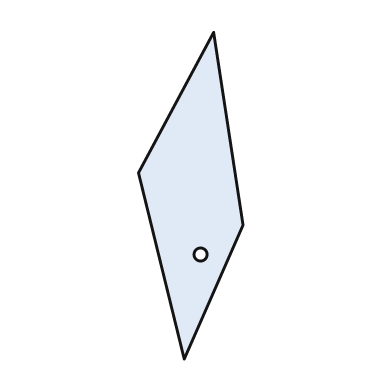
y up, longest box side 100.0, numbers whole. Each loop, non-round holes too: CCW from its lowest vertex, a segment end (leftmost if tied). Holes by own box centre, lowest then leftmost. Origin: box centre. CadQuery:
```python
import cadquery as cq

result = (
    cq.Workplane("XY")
    .moveTo(-2.0, -50.0)
    .lineTo(16.0, -9.0)
    .lineTo(7.0, 50.0)
    .lineTo(-16.0, 7.0)
    .close()
    .moveTo(3.0, -18.0)
    .circle(2.0)
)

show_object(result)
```